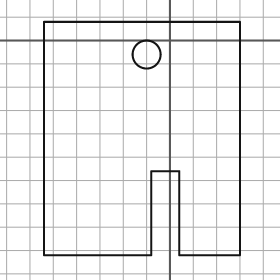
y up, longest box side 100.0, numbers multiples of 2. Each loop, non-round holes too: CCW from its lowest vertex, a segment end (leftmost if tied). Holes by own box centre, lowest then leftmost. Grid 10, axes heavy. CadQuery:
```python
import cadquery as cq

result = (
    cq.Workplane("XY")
    .moveTo(-54.0, -92.0)
    .lineTo(-8.0, -92.0)
    .lineTo(-8.0, -56.0)
    .lineTo(4.0, -56.0)
    .lineTo(4.0, -92.0)
    .lineTo(30.0, -92.0)
    .lineTo(30.0, 8.0)
    .lineTo(-54.0, 8.0)
    .close()
    .moveTo(-10.0, -6.0)
    .circle(6.0)
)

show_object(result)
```